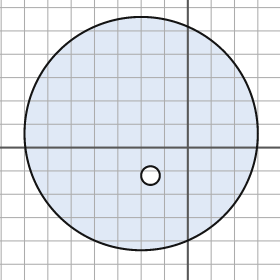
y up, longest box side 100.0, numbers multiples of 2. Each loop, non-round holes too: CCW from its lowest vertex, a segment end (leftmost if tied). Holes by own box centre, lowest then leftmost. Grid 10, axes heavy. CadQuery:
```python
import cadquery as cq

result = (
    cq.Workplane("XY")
    .moveTo(-20.0, 6.0)
    .circle(50.0)
    .moveTo(-16.0, -12.0)
    .circle(4.0)
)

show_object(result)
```